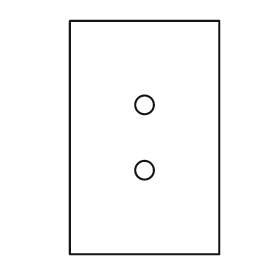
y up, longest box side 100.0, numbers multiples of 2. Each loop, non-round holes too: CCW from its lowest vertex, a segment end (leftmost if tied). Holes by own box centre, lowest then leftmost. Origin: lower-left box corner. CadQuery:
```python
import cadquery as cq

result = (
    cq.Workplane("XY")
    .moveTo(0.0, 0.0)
    .lineTo(64.0, 0.0)
    .lineTo(64.0, 100.0)
    .lineTo(0.0, 100.0)
    .close()
    .moveTo(32.0, 36.0)
    .circle(4.0)
    .moveTo(32.0, 64.0)
    .circle(4.0)
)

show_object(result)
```